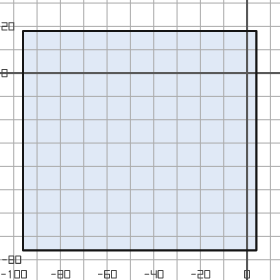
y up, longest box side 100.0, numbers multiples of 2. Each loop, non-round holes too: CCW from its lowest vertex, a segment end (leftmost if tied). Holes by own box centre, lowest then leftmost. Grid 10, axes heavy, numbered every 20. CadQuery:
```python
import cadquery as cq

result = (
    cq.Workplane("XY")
    .moveTo(-96.0, -76.0)
    .lineTo(4.0, -76.0)
    .lineTo(4.0, 18.0)
    .lineTo(-96.0, 18.0)
    .close()
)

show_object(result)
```